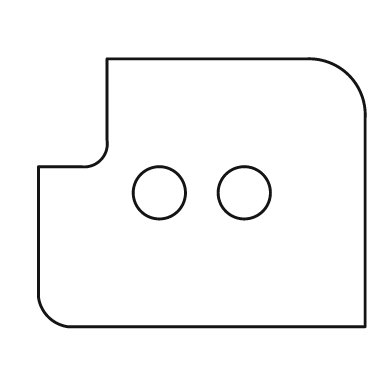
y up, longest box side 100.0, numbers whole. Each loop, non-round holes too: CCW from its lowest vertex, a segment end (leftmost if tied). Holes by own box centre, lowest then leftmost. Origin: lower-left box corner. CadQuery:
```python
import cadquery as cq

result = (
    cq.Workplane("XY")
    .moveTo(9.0, 0.0)
    .lineTo(100.0, 0.0)
    .lineTo(100.0, 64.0)
    .threePointArc((95.0, 77.0), (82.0, 82.0))
    .lineTo(21.0, 82.0)
    .lineTo(21.0, 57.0)
    .threePointArc((19.0, 51.0), (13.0, 49.0))
    .lineTo(0.0, 49.0)
    .lineTo(0.0, 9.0)
    .threePointArc((3.0, 3.0), (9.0, 0.0))
    .close()
    .moveTo(37.0, 41.0)
    .circle(8.0)
    .moveTo(63.0, 41.0)
    .circle(8.0)
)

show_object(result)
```